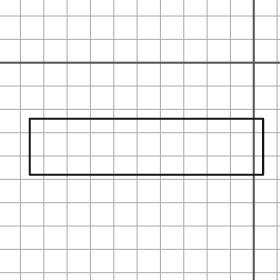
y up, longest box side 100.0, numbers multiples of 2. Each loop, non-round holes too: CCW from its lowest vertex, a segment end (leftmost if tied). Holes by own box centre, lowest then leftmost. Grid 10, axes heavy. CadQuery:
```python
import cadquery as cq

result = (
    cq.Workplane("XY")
    .moveTo(-96.0, -48.0)
    .lineTo(4.0, -48.0)
    .lineTo(4.0, -24.0)
    .lineTo(-96.0, -24.0)
    .close()
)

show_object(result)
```